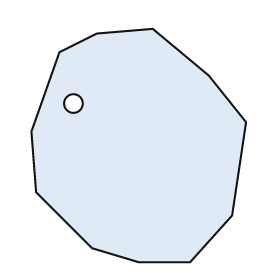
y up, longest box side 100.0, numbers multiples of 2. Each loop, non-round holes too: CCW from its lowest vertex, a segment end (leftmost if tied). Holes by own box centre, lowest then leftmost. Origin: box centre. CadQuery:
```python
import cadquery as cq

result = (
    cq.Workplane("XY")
    .moveTo(0.0, -50.0)
    .lineTo(22.0, -50.0)
    .lineTo(40.0, -30.0)
    .lineTo(46.0, 10.0)
    .lineTo(30.0, 30.0)
    .lineTo(6.0, 50.0)
    .lineTo(-18.0, 48.0)
    .lineTo(-34.0, 40.0)
    .lineTo(-46.0, 6.0)
    .lineTo(-44.0, -20.0)
    .lineTo(-20.0, -44.0)
    .close()
    .moveTo(-28.0, 18.0)
    .circle(4.0)
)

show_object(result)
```